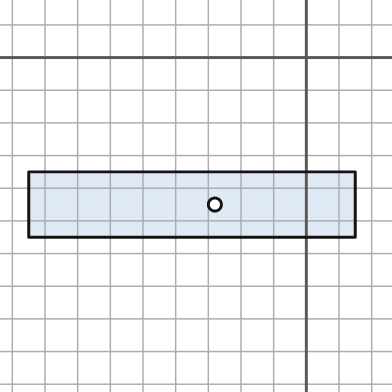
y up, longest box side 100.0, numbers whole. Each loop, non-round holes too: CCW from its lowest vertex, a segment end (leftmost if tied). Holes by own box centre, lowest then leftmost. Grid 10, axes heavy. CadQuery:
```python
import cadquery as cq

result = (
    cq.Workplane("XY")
    .moveTo(-85.0, -55.0)
    .lineTo(15.0, -55.0)
    .lineTo(15.0, -35.0)
    .lineTo(-85.0, -35.0)
    .close()
    .moveTo(-28.0, -45.0)
    .circle(2.0)
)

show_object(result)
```